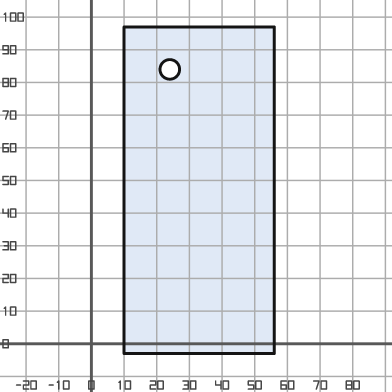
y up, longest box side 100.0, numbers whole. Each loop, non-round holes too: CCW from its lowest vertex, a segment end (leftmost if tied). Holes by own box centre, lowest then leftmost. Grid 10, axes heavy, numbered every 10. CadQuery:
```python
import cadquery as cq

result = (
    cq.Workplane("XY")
    .moveTo(10.0, -3.0)
    .lineTo(56.0, -3.0)
    .lineTo(56.0, 97.0)
    .lineTo(10.0, 97.0)
    .close()
    .moveTo(24.0, 84.0)
    .circle(3.0)
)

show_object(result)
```